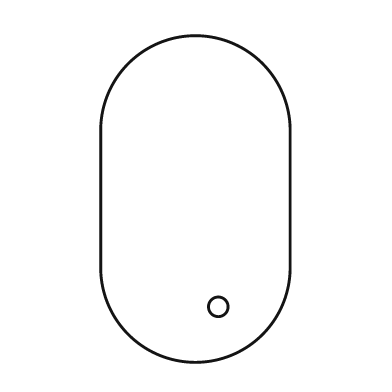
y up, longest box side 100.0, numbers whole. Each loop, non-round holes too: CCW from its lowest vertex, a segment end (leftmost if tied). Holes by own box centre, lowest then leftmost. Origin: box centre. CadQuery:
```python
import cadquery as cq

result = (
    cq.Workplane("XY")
    .moveTo(-29.0, -21.0)
    .threePointArc((0.0, -50.0), (29.0, -21.0))
    .lineTo(29.0, 21.0)
    .threePointArc((0.0, 50.0), (-29.0, 21.0))
    .close()
    .moveTo(7.0, -33.0)
    .circle(3.0)
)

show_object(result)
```